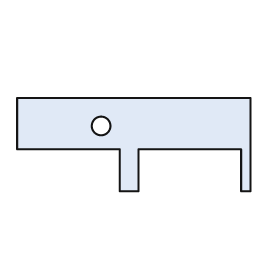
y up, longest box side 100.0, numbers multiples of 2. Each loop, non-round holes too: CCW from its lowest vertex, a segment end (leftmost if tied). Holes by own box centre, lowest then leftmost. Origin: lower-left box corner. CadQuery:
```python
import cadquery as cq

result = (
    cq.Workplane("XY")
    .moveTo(44.0, 0.0)
    .lineTo(52.0, 0.0)
    .lineTo(52.0, 18.0)
    .lineTo(96.0, 18.0)
    .lineTo(96.0, 0.0)
    .lineTo(100.0, 0.0)
    .lineTo(100.0, 40.0)
    .lineTo(0.0, 40.0)
    .lineTo(0.0, 18.0)
    .lineTo(44.0, 18.0)
    .close()
    .moveTo(36.0, 28.0)
    .circle(4.0)
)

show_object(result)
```